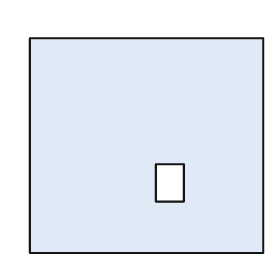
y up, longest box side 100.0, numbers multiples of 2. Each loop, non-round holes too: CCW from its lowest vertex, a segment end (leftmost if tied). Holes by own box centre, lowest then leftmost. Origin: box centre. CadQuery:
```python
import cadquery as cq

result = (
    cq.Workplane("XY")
    .moveTo(-50.0, -46.0)
    .lineTo(50.0, -46.0)
    .lineTo(50.0, 46.0)
    .lineTo(-50.0, 46.0)
    .close()
    .moveTo(4.0, -24.0)
    .lineTo(16.0, -24.0)
    .lineTo(16.0, -8.0)
    .lineTo(4.0, -8.0)
    .close()
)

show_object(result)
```